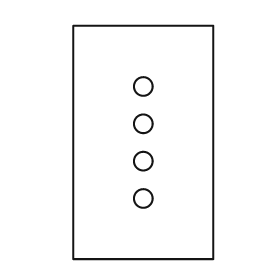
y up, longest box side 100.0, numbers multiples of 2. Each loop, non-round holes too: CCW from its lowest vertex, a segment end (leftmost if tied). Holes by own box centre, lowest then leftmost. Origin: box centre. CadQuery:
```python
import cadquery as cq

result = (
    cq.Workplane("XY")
    .moveTo(-30.0, -50.0)
    .lineTo(30.0, -50.0)
    .lineTo(30.0, 50.0)
    .lineTo(-30.0, 50.0)
    .close()
    .moveTo(0.0, -24.0)
    .circle(4.0)
    .moveTo(0.0, -8.0)
    .circle(4.0)
    .moveTo(0.0, 8.0)
    .circle(4.0)
    .moveTo(0.0, 24.0)
    .circle(4.0)
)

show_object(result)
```